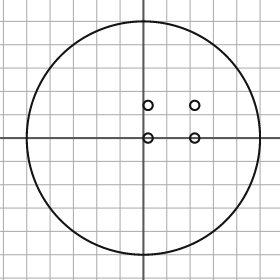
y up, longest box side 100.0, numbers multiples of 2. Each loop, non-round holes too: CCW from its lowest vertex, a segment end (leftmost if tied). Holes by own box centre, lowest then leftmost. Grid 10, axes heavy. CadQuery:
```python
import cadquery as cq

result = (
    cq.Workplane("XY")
    .moveTo(0.0, 0.0)
    .circle(50.0)
    .moveTo(2.0, 0.0)
    .circle(2.0)
    .moveTo(22.0, 0.0)
    .circle(2.0)
    .moveTo(2.0, 14.0)
    .circle(2.0)
    .moveTo(22.0, 14.0)
    .circle(2.0)
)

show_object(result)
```